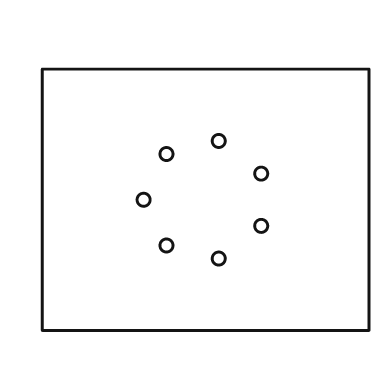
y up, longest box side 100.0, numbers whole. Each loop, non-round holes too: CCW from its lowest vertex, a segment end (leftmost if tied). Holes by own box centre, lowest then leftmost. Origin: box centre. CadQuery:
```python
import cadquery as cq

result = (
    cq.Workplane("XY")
    .moveTo(-50.0, -40.0)
    .lineTo(50.0, -40.0)
    .lineTo(50.0, 40.0)
    .lineTo(-50.0, 40.0)
    .close()
    .moveTo(4.0, -18.0)
    .circle(2.0)
    .moveTo(-12.0, -14.0)
    .circle(2.0)
    .moveTo(17.0, -8.0)
    .circle(2.0)
    .moveTo(-19.0, 0.0)
    .circle(2.0)
    .moveTo(17.0, 8.0)
    .circle(2.0)
    .moveTo(-12.0, 14.0)
    .circle(2.0)
    .moveTo(4.0, 18.0)
    .circle(2.0)
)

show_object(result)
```